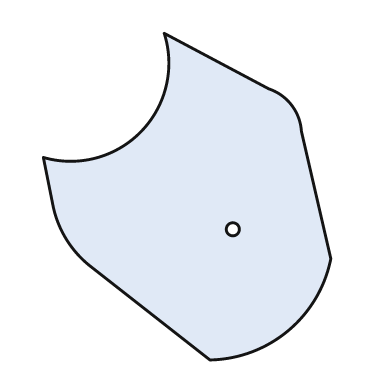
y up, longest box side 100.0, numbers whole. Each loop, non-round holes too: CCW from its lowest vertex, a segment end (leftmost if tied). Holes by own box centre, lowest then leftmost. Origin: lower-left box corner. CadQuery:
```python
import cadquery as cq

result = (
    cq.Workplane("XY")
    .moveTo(51.0, 0.0)
    .threePointArc((75.0, 9.0), (88.0, 31.0))
    .lineTo(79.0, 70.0)
    .threePointArc((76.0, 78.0), (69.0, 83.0))
    .lineTo(37.0, 100.0)
    .threePointArc((30.0, 70.0), (0.0, 62.0))
    .lineTo(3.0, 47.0)
    .threePointArc((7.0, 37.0), (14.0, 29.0))
    .close()
    .moveTo(58.0, 40.0)
    .circle(2.0)
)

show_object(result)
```